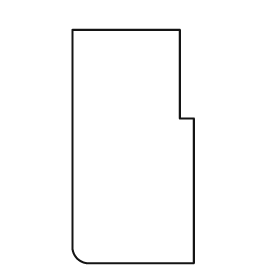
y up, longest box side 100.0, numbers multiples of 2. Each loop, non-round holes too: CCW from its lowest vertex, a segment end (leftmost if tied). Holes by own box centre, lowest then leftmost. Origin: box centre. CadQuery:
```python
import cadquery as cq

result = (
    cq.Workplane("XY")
    .moveTo(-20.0, -50.0)
    .lineTo(26.0, -50.0)
    .lineTo(26.0, 12.0)
    .lineTo(20.0, 12.0)
    .lineTo(20.0, 50.0)
    .lineTo(-26.0, 50.0)
    .lineTo(-26.0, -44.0)
    .threePointArc((-24.0, -48.0), (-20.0, -50.0))
    .close()
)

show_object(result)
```